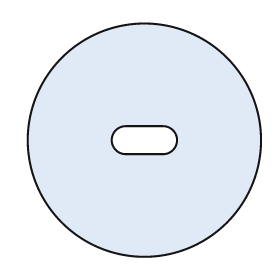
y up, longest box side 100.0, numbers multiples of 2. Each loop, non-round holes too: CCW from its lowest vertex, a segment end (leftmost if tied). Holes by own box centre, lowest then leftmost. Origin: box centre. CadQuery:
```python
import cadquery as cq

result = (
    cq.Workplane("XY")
    .moveTo(0.0, 0.0)
    .circle(50.0)
    .moveTo(-8.0, -6.0)
    .lineTo(8.0, -6.0)
    .threePointArc((14.0, 0.0), (8.0, 6.0))
    .lineTo(-8.0, 6.0)
    .threePointArc((-14.0, 0.0), (-8.0, -6.0))
    .close()
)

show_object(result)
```